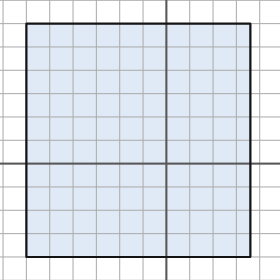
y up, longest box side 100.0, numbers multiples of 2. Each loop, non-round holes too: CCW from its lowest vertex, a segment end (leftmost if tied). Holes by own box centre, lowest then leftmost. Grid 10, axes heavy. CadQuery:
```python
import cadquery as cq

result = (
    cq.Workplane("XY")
    .moveTo(-60.0, -40.0)
    .lineTo(36.0, -40.0)
    .lineTo(36.0, 60.0)
    .lineTo(-60.0, 60.0)
    .close()
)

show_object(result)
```